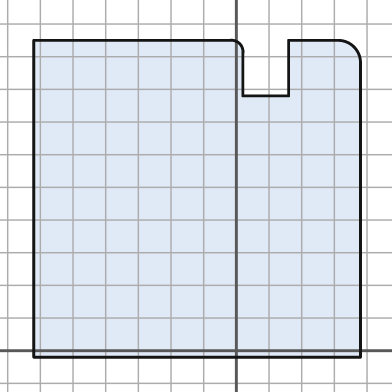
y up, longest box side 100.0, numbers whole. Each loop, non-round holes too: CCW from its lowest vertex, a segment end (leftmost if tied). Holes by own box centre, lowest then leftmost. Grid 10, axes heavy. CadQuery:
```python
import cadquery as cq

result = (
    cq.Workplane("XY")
    .moveTo(-62.0, -2.0)
    .lineTo(38.0, -2.0)
    .lineTo(38.0, 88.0)
    .threePointArc((36.0, 93.0), (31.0, 95.0))
    .lineTo(16.0, 95.0)
    .lineTo(16.0, 78.0)
    .lineTo(2.0, 78.0)
    .lineTo(2.0, 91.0)
    .threePointArc((1.0, 94.0), (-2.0, 95.0))
    .lineTo(-62.0, 95.0)
    .close()
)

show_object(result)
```